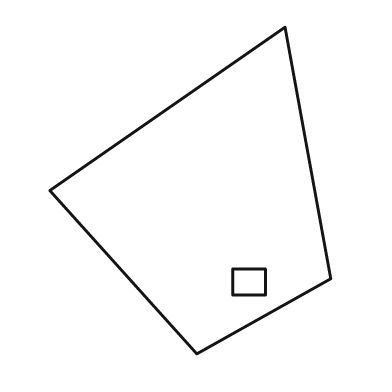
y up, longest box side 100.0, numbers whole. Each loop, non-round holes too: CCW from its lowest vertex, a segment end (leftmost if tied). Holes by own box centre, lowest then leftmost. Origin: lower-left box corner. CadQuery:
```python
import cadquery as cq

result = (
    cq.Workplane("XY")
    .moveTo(45.0, 0.0)
    .lineTo(86.0, 23.0)
    .lineTo(72.0, 100.0)
    .lineTo(0.0, 50.0)
    .close()
    .moveTo(56.0, 18.0)
    .lineTo(66.0, 18.0)
    .lineTo(66.0, 26.0)
    .lineTo(56.0, 26.0)
    .close()
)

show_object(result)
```